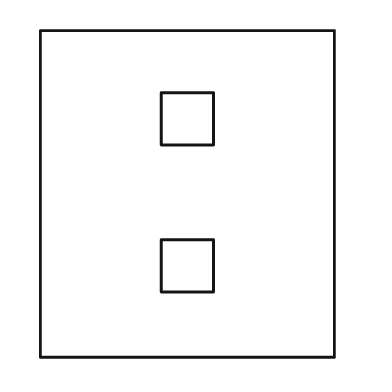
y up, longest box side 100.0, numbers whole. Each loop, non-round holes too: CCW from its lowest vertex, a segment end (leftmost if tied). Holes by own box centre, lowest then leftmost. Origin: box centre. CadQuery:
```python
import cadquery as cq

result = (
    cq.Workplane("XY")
    .moveTo(-45.0, -50.0)
    .lineTo(45.0, -50.0)
    .lineTo(45.0, 50.0)
    .lineTo(-45.0, 50.0)
    .close()
    .moveTo(-8.0, -30.0)
    .lineTo(8.0, -30.0)
    .lineTo(8.0, -14.0)
    .lineTo(-8.0, -14.0)
    .close()
    .moveTo(-8.0, 15.0)
    .lineTo(8.0, 15.0)
    .lineTo(8.0, 31.0)
    .lineTo(-8.0, 31.0)
    .close()
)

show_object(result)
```